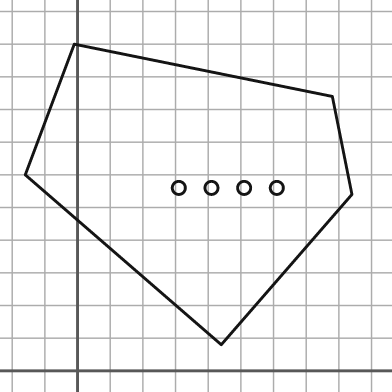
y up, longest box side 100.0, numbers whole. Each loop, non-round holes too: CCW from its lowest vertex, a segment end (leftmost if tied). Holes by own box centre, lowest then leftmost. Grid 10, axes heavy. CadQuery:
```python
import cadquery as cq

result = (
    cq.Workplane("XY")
    .moveTo(44.0, 8.0)
    .lineTo(84.0, 54.0)
    .lineTo(78.0, 84.0)
    .lineTo(-1.0, 100.0)
    .lineTo(-16.0, 60.0)
    .close()
    .moveTo(31.0, 56.0)
    .circle(2.0)
    .moveTo(41.0, 56.0)
    .circle(2.0)
    .moveTo(51.0, 56.0)
    .circle(2.0)
    .moveTo(61.0, 56.0)
    .circle(2.0)
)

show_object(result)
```